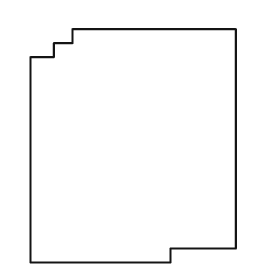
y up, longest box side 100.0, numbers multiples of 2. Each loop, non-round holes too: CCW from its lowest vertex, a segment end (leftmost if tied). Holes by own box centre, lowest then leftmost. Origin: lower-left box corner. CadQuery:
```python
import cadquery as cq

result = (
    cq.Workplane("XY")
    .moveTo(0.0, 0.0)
    .lineTo(60.0, 0.0)
    .lineTo(60.0, 6.0)
    .lineTo(88.0, 6.0)
    .lineTo(88.0, 100.0)
    .lineTo(18.0, 100.0)
    .lineTo(18.0, 94.0)
    .lineTo(10.0, 94.0)
    .lineTo(10.0, 88.0)
    .lineTo(0.0, 88.0)
    .close()
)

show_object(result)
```